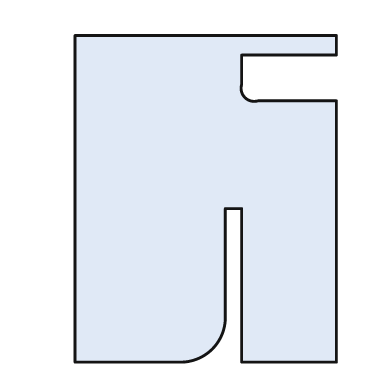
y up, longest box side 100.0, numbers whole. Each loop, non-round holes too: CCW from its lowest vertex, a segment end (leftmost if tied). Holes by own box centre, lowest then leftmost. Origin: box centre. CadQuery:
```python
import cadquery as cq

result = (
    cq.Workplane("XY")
    .moveTo(-40.0, -50.0)
    .lineTo(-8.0, -50.0)
    .threePointArc((2.0, -46.0), (6.0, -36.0))
    .lineTo(6.0, -3.0)
    .lineTo(11.0, -3.0)
    .lineTo(11.0, -50.0)
    .lineTo(40.0, -50.0)
    .lineTo(40.0, 30.0)
    .lineTo(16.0, 30.0)
    .threePointArc((12.0, 31.0), (11.0, 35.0))
    .lineTo(11.0, 44.0)
    .lineTo(40.0, 44.0)
    .lineTo(40.0, 50.0)
    .lineTo(-40.0, 50.0)
    .close()
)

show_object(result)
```